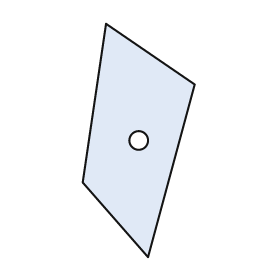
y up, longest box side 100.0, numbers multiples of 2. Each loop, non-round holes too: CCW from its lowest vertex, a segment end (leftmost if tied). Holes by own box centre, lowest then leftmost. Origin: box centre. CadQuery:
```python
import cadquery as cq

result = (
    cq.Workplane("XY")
    .moveTo(4.0, -50.0)
    .lineTo(24.0, 24.0)
    .lineTo(-14.0, 50.0)
    .lineTo(-24.0, -18.0)
    .close()
    .moveTo(0.0, 0.0)
    .circle(4.0)
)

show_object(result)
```